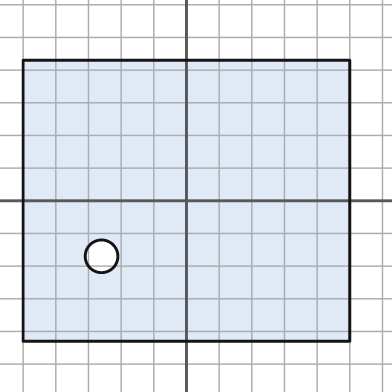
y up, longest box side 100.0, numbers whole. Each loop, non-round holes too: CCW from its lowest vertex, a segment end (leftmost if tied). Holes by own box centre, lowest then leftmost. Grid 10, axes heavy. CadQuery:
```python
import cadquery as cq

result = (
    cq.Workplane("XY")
    .moveTo(-50.0, -43.0)
    .lineTo(50.0, -43.0)
    .lineTo(50.0, 43.0)
    .lineTo(-50.0, 43.0)
    .close()
    .moveTo(-26.0, -17.0)
    .circle(5.0)
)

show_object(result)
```